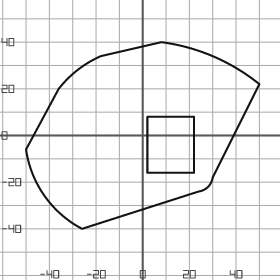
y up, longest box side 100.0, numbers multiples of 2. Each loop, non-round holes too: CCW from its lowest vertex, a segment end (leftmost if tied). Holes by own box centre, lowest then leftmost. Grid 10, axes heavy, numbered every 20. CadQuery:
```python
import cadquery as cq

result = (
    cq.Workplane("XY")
    .moveTo(-26.0, -40.0)
    .lineTo(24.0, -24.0)
    .threePointArc((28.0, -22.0), (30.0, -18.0))
    .lineTo(50.0, 22.0)
    .threePointArc((30.0, 34.0), (8.0, 40.0))
    .lineTo(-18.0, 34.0)
    .threePointArc((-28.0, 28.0), (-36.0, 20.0))
    .lineTo(-50.0, -6.0)
    .threePointArc((-42.0, -26.0), (-26.0, -40.0))
    .close()
    .moveTo(2.0, -16.0)
    .lineTo(22.0, -16.0)
    .lineTo(22.0, 8.0)
    .lineTo(2.0, 8.0)
    .close()
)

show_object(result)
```